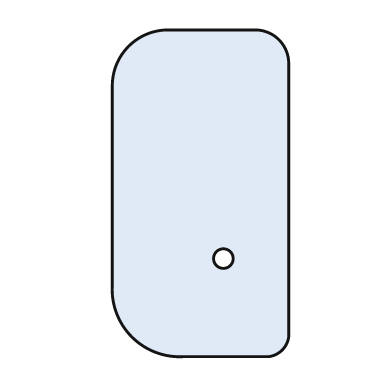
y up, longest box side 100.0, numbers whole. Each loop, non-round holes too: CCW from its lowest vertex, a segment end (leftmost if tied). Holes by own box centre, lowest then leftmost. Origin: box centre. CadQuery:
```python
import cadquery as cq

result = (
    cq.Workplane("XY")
    .moveTo(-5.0, -50.0)
    .lineTo(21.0, -50.0)
    .threePointArc((25.0, -48.0), (27.0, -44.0))
    .lineTo(27.0, 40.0)
    .threePointArc((24.0, 47.0), (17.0, 50.0))
    .lineTo(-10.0, 50.0)
    .threePointArc((-22.0, 45.0), (-27.0, 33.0))
    .lineTo(-27.0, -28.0)
    .threePointArc((-21.0, -44.0), (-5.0, -50.0))
    .close()
    .moveTo(7.0, -20.0)
    .circle(3.0)
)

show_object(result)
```